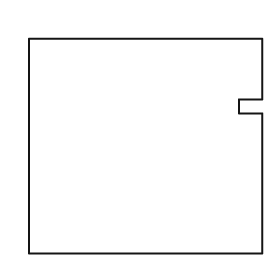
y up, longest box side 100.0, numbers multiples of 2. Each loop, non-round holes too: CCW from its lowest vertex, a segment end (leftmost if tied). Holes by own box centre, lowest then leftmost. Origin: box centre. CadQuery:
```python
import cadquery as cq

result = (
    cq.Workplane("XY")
    .moveTo(-50.0, -46.0)
    .lineTo(50.0, -46.0)
    .lineTo(50.0, 14.0)
    .lineTo(40.0, 14.0)
    .lineTo(40.0, 20.0)
    .lineTo(50.0, 20.0)
    .lineTo(50.0, 46.0)
    .lineTo(-50.0, 46.0)
    .close()
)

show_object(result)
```